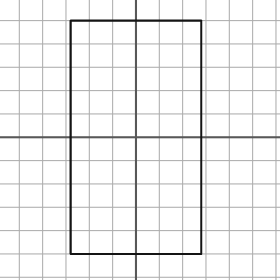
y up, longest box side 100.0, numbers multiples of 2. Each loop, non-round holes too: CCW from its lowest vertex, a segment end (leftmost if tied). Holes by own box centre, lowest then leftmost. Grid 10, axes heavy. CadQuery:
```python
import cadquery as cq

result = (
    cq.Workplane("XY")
    .moveTo(-28.0, -50.0)
    .lineTo(28.0, -50.0)
    .lineTo(28.0, 50.0)
    .lineTo(-28.0, 50.0)
    .close()
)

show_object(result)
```